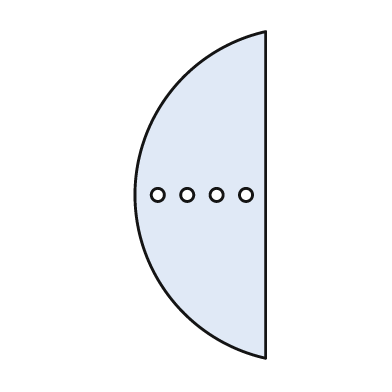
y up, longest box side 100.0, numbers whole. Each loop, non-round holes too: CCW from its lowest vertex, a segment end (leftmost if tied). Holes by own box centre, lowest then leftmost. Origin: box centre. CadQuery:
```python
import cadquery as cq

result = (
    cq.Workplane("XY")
    .moveTo(20.0, -50.0)
    .lineTo(20.0, 50.0)
    .threePointArc((-20.0, 0.0), (20.0, -50.0))
    .close()
    .moveTo(-13.0, 0.0)
    .circle(2.0)
    .moveTo(-4.0, 0.0)
    .circle(2.0)
    .moveTo(5.0, 0.0)
    .circle(2.0)
    .moveTo(14.0, 0.0)
    .circle(2.0)
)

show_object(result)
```